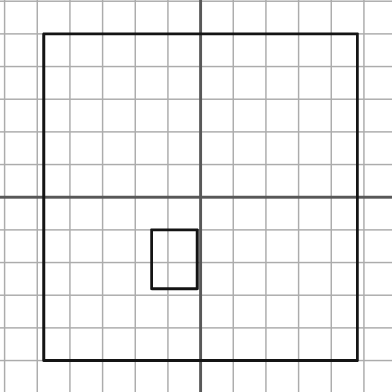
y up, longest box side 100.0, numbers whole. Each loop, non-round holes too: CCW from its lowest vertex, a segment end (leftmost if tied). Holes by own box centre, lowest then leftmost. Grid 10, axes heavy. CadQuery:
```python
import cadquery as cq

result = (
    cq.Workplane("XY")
    .moveTo(-48.0, -50.0)
    .lineTo(48.0, -50.0)
    .lineTo(48.0, 50.0)
    .lineTo(-48.0, 50.0)
    .close()
    .moveTo(-15.0, -28.0)
    .lineTo(-1.0, -28.0)
    .lineTo(-1.0, -10.0)
    .lineTo(-15.0, -10.0)
    .close()
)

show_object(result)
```